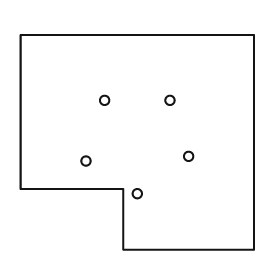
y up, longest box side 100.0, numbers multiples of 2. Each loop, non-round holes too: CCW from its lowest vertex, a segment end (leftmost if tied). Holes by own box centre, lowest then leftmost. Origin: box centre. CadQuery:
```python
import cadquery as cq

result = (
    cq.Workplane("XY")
    .moveTo(-6.0, -46.0)
    .lineTo(50.0, -46.0)
    .lineTo(50.0, 46.0)
    .lineTo(-50.0, 46.0)
    .lineTo(-50.0, -20.0)
    .lineTo(-6.0, -20.0)
    .close()
    .moveTo(0.0, -22.0)
    .circle(2.0)
    .moveTo(-22.0, -8.0)
    .circle(2.0)
    .moveTo(22.0, -6.0)
    .circle(2.0)
    .moveTo(-14.0, 18.0)
    .circle(2.0)
    .moveTo(14.0, 18.0)
    .circle(2.0)
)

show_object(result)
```